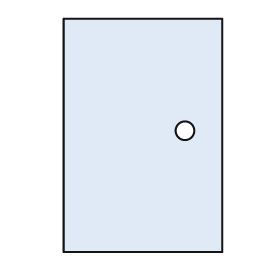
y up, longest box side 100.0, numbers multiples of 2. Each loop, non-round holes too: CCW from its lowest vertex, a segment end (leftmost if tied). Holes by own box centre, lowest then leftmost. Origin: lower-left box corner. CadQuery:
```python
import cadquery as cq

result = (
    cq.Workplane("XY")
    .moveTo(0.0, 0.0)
    .lineTo(68.0, 0.0)
    .lineTo(68.0, 100.0)
    .lineTo(0.0, 100.0)
    .close()
    .moveTo(52.0, 52.0)
    .circle(4.0)
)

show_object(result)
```